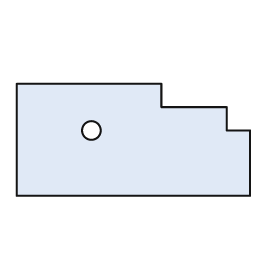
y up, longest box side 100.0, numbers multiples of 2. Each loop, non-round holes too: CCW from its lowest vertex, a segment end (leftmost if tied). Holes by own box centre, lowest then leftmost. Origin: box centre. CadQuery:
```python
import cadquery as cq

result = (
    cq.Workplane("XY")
    .moveTo(-50.0, -24.0)
    .lineTo(50.0, -24.0)
    .lineTo(50.0, 4.0)
    .lineTo(40.0, 4.0)
    .lineTo(40.0, 14.0)
    .lineTo(12.0, 14.0)
    .lineTo(12.0, 24.0)
    .lineTo(-50.0, 24.0)
    .close()
    .moveTo(-18.0, 4.0)
    .circle(4.0)
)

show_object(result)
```